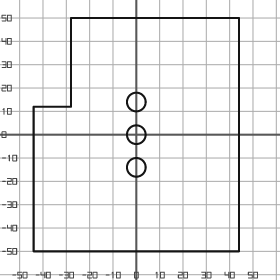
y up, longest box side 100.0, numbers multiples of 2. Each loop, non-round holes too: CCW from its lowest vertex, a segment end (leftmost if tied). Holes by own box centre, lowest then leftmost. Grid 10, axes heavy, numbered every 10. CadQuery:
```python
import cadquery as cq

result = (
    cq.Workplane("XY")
    .moveTo(-44.0, -50.0)
    .lineTo(44.0, -50.0)
    .lineTo(44.0, 50.0)
    .lineTo(-28.0, 50.0)
    .lineTo(-28.0, 12.0)
    .lineTo(-44.0, 12.0)
    .close()
    .moveTo(0.0, -14.0)
    .circle(4.0)
    .moveTo(0.0, 0.0)
    .circle(4.0)
    .moveTo(0.0, 14.0)
    .circle(4.0)
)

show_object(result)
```